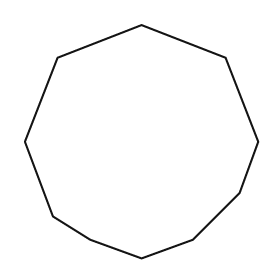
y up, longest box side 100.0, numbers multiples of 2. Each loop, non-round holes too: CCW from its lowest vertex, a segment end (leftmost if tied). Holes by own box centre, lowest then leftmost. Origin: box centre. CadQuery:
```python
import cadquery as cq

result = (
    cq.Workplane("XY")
    .moveTo(0.0, -50.0)
    .lineTo(22.0, -42.0)
    .lineTo(42.0, -22.0)
    .lineTo(50.0, 0.0)
    .lineTo(36.0, 36.0)
    .lineTo(0.0, 50.0)
    .lineTo(-36.0, 36.0)
    .lineTo(-50.0, 0.0)
    .lineTo(-38.0, -32.0)
    .lineTo(-22.0, -42.0)
    .close()
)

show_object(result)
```